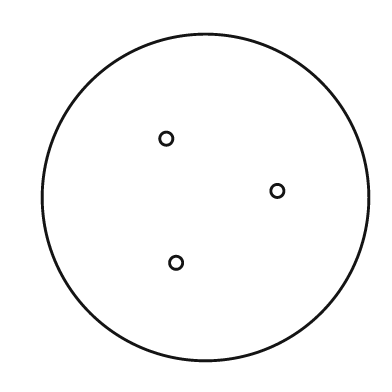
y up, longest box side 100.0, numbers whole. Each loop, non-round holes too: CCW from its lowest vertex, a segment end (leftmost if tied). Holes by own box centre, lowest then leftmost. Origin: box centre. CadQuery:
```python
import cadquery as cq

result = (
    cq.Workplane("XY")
    .moveTo(0.0, 0.0)
    .circle(50.0)
    .moveTo(-9.0, -20.0)
    .circle(2.0)
    .moveTo(22.0, 2.0)
    .circle(2.0)
    .moveTo(-12.0, 18.0)
    .circle(2.0)
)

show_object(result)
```